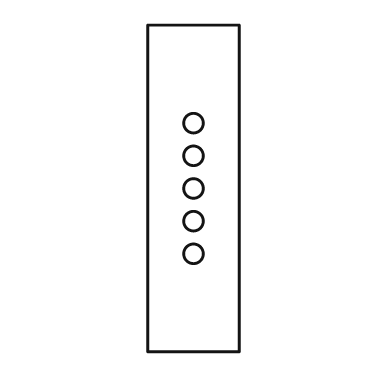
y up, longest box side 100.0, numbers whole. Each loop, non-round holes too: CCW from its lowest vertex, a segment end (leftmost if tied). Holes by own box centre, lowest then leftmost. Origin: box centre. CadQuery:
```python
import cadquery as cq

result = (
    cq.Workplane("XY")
    .moveTo(-14.0, -50.0)
    .lineTo(14.0, -50.0)
    .lineTo(14.0, 50.0)
    .lineTo(-14.0, 50.0)
    .close()
    .moveTo(0.0, -20.0)
    .circle(3.0)
    .moveTo(0.0, -10.0)
    .circle(3.0)
    .moveTo(0.0, 0.0)
    .circle(3.0)
    .moveTo(0.0, 10.0)
    .circle(3.0)
    .moveTo(0.0, 20.0)
    .circle(3.0)
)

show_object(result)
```